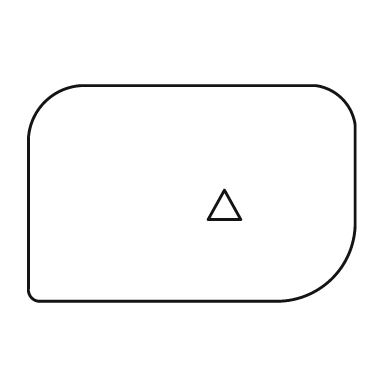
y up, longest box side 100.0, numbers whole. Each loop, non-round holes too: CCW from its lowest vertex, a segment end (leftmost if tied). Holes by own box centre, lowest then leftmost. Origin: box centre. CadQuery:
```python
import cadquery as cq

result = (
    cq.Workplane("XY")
    .moveTo(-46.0, -33.0)
    .lineTo(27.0, -33.0)
    .threePointArc((43.0, -26.0), (50.0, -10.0))
    .lineTo(50.0, 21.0)
    .threePointArc((46.0, 29.0), (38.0, 33.0))
    .lineTo(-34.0, 33.0)
    .threePointArc((-45.0, 28.0), (-50.0, 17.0))
    .lineTo(-50.0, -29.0)
    .threePointArc((-49.0, -32.0), (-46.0, -33.0))
    .close()
    .moveTo(5.0, -8.0)
    .lineTo(15.0, -8.0)
    .lineTo(10.0, 1.0)
    .close()
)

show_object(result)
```